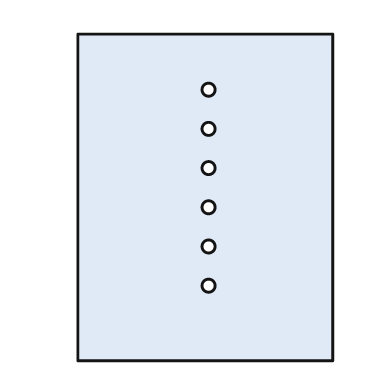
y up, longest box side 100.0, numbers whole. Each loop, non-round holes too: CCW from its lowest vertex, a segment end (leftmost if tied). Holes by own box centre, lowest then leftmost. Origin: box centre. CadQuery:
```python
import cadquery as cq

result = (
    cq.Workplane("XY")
    .moveTo(-39.0, -50.0)
    .lineTo(39.0, -50.0)
    .lineTo(39.0, 50.0)
    .lineTo(-39.0, 50.0)
    .close()
    .moveTo(1.0, -27.0)
    .circle(2.0)
    .moveTo(1.0, -15.0)
    .circle(2.0)
    .moveTo(1.0, -3.0)
    .circle(2.0)
    .moveTo(1.0, 9.0)
    .circle(2.0)
    .moveTo(1.0, 21.0)
    .circle(2.0)
    .moveTo(1.0, 33.0)
    .circle(2.0)
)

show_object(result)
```